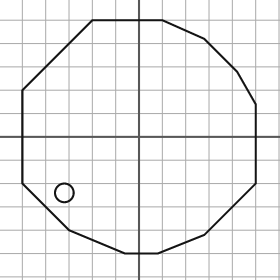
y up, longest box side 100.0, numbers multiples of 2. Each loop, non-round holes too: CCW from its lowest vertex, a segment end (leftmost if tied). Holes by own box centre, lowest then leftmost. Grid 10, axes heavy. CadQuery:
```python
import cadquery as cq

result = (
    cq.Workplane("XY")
    .moveTo(-6.0, -50.0)
    .lineTo(8.0, -50.0)
    .lineTo(28.0, -42.0)
    .lineTo(50.0, -20.0)
    .lineTo(50.0, 14.0)
    .lineTo(42.0, 28.0)
    .lineTo(28.0, 42.0)
    .lineTo(10.0, 50.0)
    .lineTo(-20.0, 50.0)
    .lineTo(-50.0, 20.0)
    .lineTo(-50.0, -20.0)
    .lineTo(-30.0, -40.0)
    .close()
    .moveTo(-32.0, -24.0)
    .circle(4.0)
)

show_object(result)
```